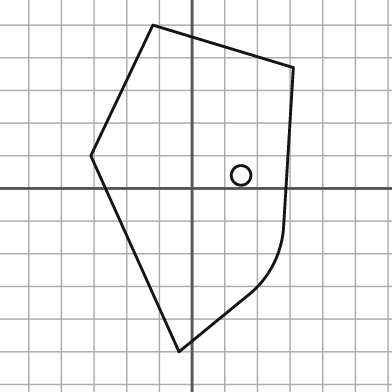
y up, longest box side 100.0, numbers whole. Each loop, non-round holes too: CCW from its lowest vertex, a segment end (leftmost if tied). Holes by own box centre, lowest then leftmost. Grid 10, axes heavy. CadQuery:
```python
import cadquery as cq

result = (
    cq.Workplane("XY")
    .moveTo(-4.0, -50.0)
    .lineTo(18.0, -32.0)
    .threePointArc((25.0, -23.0), (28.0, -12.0))
    .lineTo(31.0, 37.0)
    .lineTo(-12.0, 50.0)
    .lineTo(-31.0, 10.0)
    .close()
    .moveTo(15.0, 4.0)
    .circle(3.0)
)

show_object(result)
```